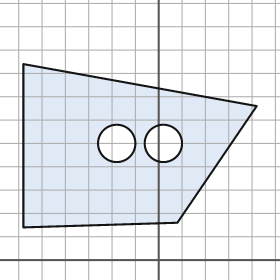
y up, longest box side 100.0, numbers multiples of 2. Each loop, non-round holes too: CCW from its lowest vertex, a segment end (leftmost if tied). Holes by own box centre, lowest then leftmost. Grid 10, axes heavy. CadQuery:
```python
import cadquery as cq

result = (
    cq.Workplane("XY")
    .moveTo(-58.0, 14.0)
    .lineTo(8.0, 16.0)
    .lineTo(42.0, 66.0)
    .lineTo(-58.0, 84.0)
    .close()
    .moveTo(-18.0, 50.0)
    .circle(8.0)
    .moveTo(2.0, 50.0)
    .circle(8.0)
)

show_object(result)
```